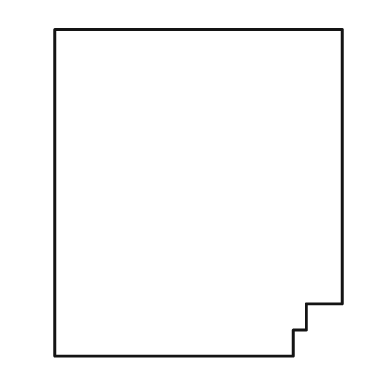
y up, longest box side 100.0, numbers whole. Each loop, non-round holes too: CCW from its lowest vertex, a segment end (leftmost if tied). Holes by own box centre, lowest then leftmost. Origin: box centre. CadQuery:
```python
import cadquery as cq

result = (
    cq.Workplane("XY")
    .moveTo(-44.0, -50.0)
    .lineTo(29.0, -50.0)
    .lineTo(29.0, -42.0)
    .lineTo(33.0, -42.0)
    .lineTo(33.0, -34.0)
    .lineTo(44.0, -34.0)
    .lineTo(44.0, 50.0)
    .lineTo(-44.0, 50.0)
    .close()
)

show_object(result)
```